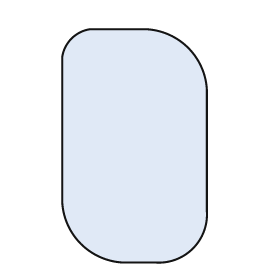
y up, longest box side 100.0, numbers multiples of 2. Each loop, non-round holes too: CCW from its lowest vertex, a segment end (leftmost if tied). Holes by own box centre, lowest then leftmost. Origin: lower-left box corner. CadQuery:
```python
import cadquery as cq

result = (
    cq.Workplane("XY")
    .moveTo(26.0, 0.0)
    .lineTo(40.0, 0.0)
    .threePointArc((56.0, 6.0), (62.0, 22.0))
    .lineTo(62.0, 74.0)
    .threePointArc((54.0, 92.0), (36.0, 100.0))
    .lineTo(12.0, 100.0)
    .threePointArc((4.0, 96.0), (0.0, 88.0))
    .lineTo(0.0, 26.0)
    .threePointArc((8.0, 8.0), (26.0, 0.0))
    .close()
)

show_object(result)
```